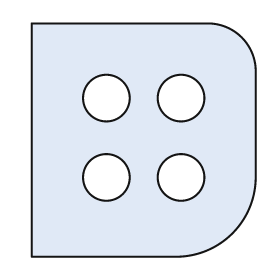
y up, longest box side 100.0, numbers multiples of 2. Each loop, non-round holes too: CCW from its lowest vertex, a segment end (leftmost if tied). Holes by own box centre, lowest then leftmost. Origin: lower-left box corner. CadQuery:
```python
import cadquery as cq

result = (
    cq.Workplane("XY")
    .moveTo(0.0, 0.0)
    .lineTo(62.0, 0.0)
    .threePointArc((86.0, 10.0), (96.0, 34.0))
    .lineTo(96.0, 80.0)
    .threePointArc((90.0, 94.0), (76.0, 100.0))
    .lineTo(0.0, 100.0)
    .close()
    .moveTo(32.0, 34.0)
    .circle(10.0)
    .moveTo(64.0, 34.0)
    .circle(10.0)
    .moveTo(32.0, 68.0)
    .circle(10.0)
    .moveTo(64.0, 68.0)
    .circle(10.0)
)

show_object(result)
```